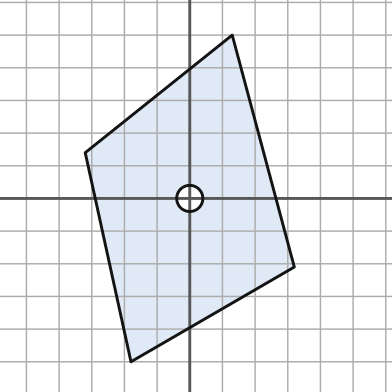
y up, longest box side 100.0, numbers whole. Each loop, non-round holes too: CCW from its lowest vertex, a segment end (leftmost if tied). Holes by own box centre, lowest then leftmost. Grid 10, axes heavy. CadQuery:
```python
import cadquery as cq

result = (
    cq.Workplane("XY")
    .moveTo(-18.0, -50.0)
    .lineTo(32.0, -21.0)
    .lineTo(13.0, 50.0)
    .lineTo(-32.0, 14.0)
    .close()
    .moveTo(0.0, 0.0)
    .circle(4.0)
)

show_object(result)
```